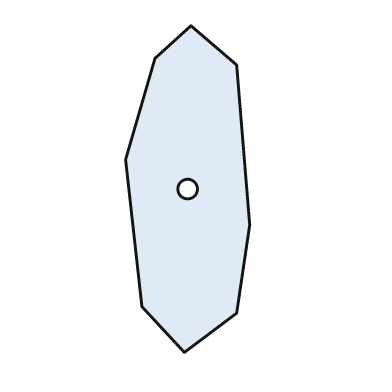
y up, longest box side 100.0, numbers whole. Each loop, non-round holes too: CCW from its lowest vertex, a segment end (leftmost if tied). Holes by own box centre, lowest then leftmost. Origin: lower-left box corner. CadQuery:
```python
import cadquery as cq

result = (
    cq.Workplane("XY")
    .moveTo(18.0, 0.0)
    .lineTo(34.0, 12.0)
    .lineTo(38.0, 39.0)
    .lineTo(34.0, 88.0)
    .lineTo(20.0, 100.0)
    .lineTo(9.0, 90.0)
    .lineTo(0.0, 59.0)
    .lineTo(5.0, 14.0)
    .close()
    .moveTo(19.0, 50.0)
    .circle(3.0)
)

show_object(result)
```